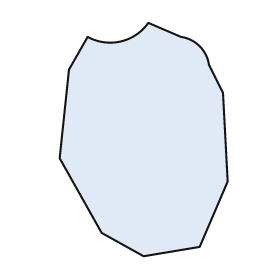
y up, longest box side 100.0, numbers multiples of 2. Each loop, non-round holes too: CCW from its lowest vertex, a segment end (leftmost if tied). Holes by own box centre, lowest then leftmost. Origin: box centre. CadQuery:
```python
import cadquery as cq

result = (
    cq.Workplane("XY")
    .moveTo(0.0, -50.0)
    .lineTo(24.0, -46.0)
    .lineTo(36.0, -18.0)
    .lineTo(34.0, 20.0)
    .lineTo(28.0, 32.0)
    .threePointArc((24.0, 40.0), (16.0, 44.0))
    .lineTo(2.0, 50.0)
    .threePointArc((-10.0, 42.0), (-24.0, 44.0))
    .lineTo(-32.0, 30.0)
    .lineTo(-36.0, -8.0)
    .lineTo(-18.0, -40.0)
    .close()
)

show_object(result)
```